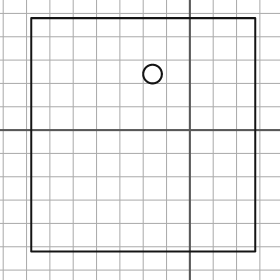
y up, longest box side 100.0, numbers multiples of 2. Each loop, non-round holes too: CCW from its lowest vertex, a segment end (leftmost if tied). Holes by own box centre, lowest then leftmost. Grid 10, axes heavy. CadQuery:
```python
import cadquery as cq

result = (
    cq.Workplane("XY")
    .moveTo(-68.0, -52.0)
    .lineTo(28.0, -52.0)
    .lineTo(28.0, 48.0)
    .lineTo(-68.0, 48.0)
    .close()
    .moveTo(-16.0, 24.0)
    .circle(4.0)
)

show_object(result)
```